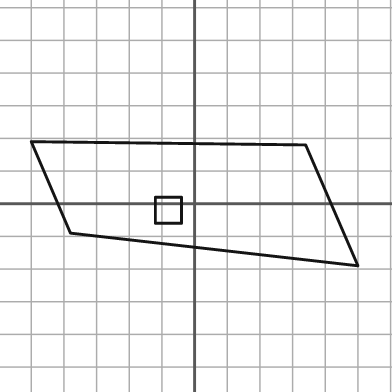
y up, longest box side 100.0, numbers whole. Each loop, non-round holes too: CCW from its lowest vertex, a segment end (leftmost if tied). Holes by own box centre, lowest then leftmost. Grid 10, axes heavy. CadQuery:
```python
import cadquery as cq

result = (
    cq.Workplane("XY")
    .moveTo(50.0, -19.0)
    .lineTo(34.0, 18.0)
    .lineTo(-50.0, 19.0)
    .lineTo(-38.0, -9.0)
    .close()
    .moveTo(-12.0, -6.0)
    .lineTo(-4.0, -6.0)
    .lineTo(-4.0, 2.0)
    .lineTo(-12.0, 2.0)
    .close()
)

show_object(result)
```